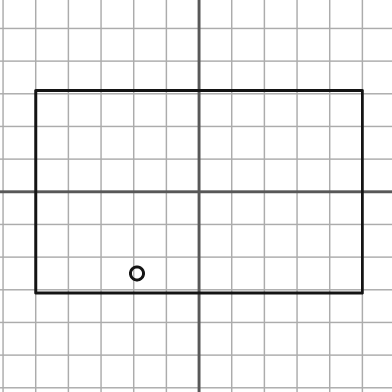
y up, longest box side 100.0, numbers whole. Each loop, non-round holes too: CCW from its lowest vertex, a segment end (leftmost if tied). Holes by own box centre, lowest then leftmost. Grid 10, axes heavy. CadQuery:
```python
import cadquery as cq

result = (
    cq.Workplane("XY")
    .moveTo(-50.0, -31.0)
    .lineTo(50.0, -31.0)
    .lineTo(50.0, 31.0)
    .lineTo(-50.0, 31.0)
    .close()
    .moveTo(-19.0, -25.0)
    .circle(2.0)
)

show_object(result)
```